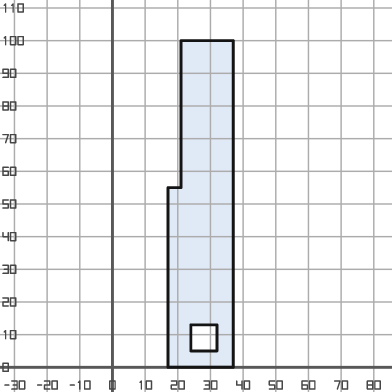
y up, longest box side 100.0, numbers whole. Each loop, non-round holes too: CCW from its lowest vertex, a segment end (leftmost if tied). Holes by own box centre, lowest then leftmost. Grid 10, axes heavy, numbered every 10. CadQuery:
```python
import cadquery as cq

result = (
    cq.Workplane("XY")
    .moveTo(17.0, 0.0)
    .lineTo(37.0, 0.0)
    .lineTo(37.0, 100.0)
    .lineTo(21.0, 100.0)
    .lineTo(21.0, 55.0)
    .lineTo(17.0, 55.0)
    .close()
    .moveTo(24.0, 5.0)
    .lineTo(32.0, 5.0)
    .lineTo(32.0, 13.0)
    .lineTo(24.0, 13.0)
    .close()
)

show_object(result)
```